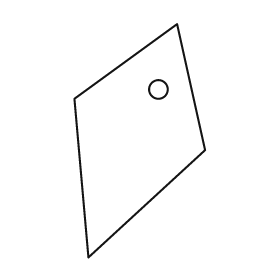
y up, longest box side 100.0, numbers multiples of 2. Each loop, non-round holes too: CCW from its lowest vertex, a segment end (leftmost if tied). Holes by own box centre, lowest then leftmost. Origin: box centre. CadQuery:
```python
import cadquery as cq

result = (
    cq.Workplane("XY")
    .moveTo(-22.0, -50.0)
    .lineTo(28.0, -4.0)
    .lineTo(16.0, 50.0)
    .lineTo(-28.0, 18.0)
    .close()
    .moveTo(8.0, 22.0)
    .circle(4.0)
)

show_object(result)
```